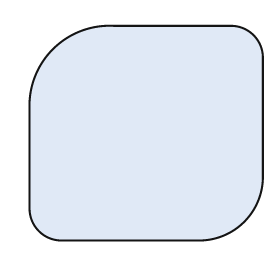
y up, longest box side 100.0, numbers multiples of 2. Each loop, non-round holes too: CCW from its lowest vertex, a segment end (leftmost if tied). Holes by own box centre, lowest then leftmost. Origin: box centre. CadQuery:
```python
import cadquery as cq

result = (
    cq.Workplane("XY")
    .moveTo(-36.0, -46.0)
    .lineTo(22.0, -46.0)
    .threePointArc((42.0, -38.0), (50.0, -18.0))
    .lineTo(50.0, 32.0)
    .threePointArc((46.0, 42.0), (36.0, 46.0))
    .lineTo(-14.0, 46.0)
    .threePointArc((-40.0, 36.0), (-50.0, 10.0))
    .lineTo(-50.0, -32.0)
    .threePointArc((-46.0, -42.0), (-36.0, -46.0))
    .close()
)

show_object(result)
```